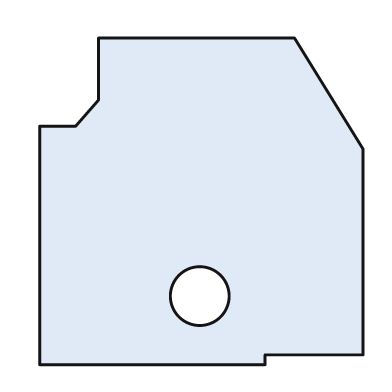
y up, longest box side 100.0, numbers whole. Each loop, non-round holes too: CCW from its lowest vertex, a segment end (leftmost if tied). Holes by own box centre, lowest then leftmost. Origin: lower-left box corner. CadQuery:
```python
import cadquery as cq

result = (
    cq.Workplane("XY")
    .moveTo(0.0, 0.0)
    .lineTo(69.0, 0.0)
    .lineTo(69.0, 3.0)
    .lineTo(99.0, 3.0)
    .lineTo(99.0, 66.0)
    .lineTo(78.0, 100.0)
    .lineTo(18.0, 100.0)
    .lineTo(18.0, 81.0)
    .lineTo(11.0, 73.0)
    .lineTo(0.0, 73.0)
    .close()
    .moveTo(49.0, 21.0)
    .circle(9.0)
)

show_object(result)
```